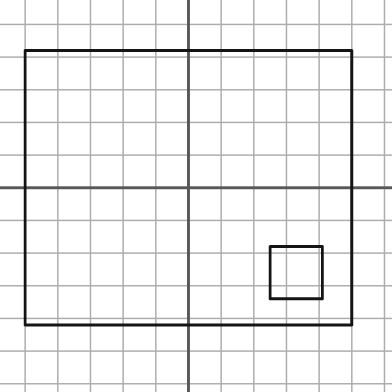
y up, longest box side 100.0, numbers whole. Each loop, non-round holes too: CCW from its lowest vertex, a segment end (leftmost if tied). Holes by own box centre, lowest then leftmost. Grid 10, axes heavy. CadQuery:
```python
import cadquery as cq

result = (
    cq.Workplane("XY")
    .moveTo(-50.0, -42.0)
    .lineTo(50.0, -42.0)
    .lineTo(50.0, 42.0)
    .lineTo(-50.0, 42.0)
    .close()
    .moveTo(25.0, -34.0)
    .lineTo(41.0, -34.0)
    .lineTo(41.0, -18.0)
    .lineTo(25.0, -18.0)
    .close()
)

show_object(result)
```